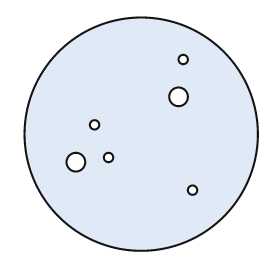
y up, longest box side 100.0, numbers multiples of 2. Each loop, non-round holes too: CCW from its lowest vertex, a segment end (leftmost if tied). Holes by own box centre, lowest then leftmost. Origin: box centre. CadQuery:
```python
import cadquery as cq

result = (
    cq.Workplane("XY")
    .moveTo(0.0, 0.0)
    .circle(50.0)
    .moveTo(22.0, -24.0)
    .circle(2.0)
    .moveTo(-28.0, -12.0)
    .circle(4.0)
    .moveTo(-14.0, -10.0)
    .circle(2.0)
    .moveTo(-20.0, 4.0)
    .circle(2.0)
    .moveTo(16.0, 16.0)
    .circle(4.0)
    .moveTo(18.0, 32.0)
    .circle(2.0)
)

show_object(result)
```